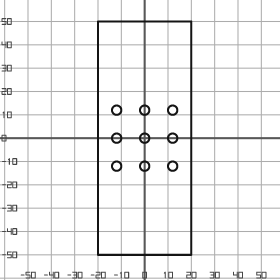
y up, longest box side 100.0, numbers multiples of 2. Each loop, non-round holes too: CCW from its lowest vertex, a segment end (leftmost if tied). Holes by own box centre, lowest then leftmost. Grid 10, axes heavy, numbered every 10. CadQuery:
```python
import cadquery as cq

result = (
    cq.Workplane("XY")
    .moveTo(-20.0, -50.0)
    .lineTo(20.0, -50.0)
    .lineTo(20.0, 50.0)
    .lineTo(-20.0, 50.0)
    .close()
    .moveTo(-12.0, -12.0)
    .circle(2.0)
    .moveTo(0.0, -12.0)
    .circle(2.0)
    .moveTo(12.0, -12.0)
    .circle(2.0)
    .moveTo(-12.0, 0.0)
    .circle(2.0)
    .moveTo(0.0, 0.0)
    .circle(2.0)
    .moveTo(12.0, 0.0)
    .circle(2.0)
    .moveTo(-12.0, 12.0)
    .circle(2.0)
    .moveTo(0.0, 12.0)
    .circle(2.0)
    .moveTo(12.0, 12.0)
    .circle(2.0)
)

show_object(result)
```